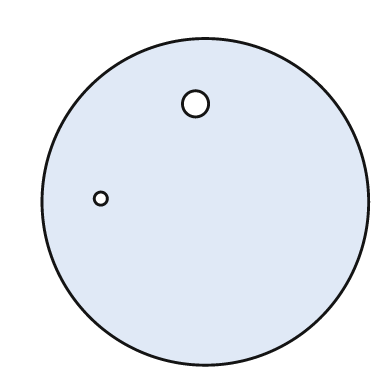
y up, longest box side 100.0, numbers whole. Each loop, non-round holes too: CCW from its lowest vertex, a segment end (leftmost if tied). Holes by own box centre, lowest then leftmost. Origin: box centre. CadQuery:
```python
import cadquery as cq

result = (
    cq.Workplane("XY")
    .moveTo(0.0, 0.0)
    .circle(50.0)
    .moveTo(-32.0, 1.0)
    .circle(2.0)
    .moveTo(-3.0, 30.0)
    .circle(4.0)
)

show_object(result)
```